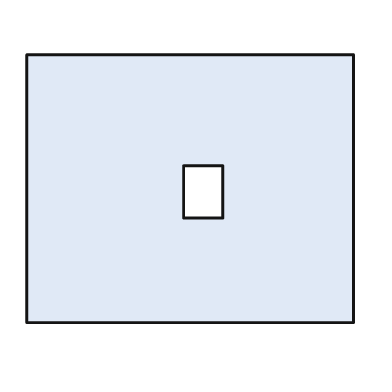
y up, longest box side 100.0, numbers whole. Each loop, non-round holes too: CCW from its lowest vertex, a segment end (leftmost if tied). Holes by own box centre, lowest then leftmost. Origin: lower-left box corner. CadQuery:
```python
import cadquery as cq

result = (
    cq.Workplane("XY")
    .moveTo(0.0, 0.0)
    .lineTo(100.0, 0.0)
    .lineTo(100.0, 82.0)
    .lineTo(0.0, 82.0)
    .close()
    .moveTo(48.0, 32.0)
    .lineTo(60.0, 32.0)
    .lineTo(60.0, 48.0)
    .lineTo(48.0, 48.0)
    .close()
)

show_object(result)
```